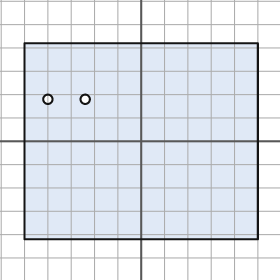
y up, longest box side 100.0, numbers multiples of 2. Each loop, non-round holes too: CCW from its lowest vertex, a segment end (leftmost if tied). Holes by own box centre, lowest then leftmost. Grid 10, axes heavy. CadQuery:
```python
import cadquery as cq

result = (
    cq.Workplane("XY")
    .moveTo(-50.0, -42.0)
    .lineTo(50.0, -42.0)
    .lineTo(50.0, 42.0)
    .lineTo(-50.0, 42.0)
    .close()
    .moveTo(-40.0, 18.0)
    .circle(2.0)
    .moveTo(-24.0, 18.0)
    .circle(2.0)
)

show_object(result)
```